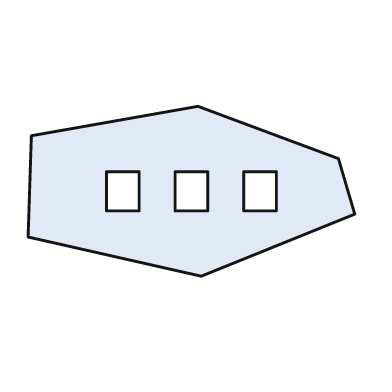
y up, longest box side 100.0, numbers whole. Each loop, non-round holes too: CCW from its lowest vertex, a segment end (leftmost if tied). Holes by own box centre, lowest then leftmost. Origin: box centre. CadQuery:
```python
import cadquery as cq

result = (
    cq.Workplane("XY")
    .moveTo(3.0, -26.0)
    .lineTo(50.0, -7.0)
    .lineTo(45.0, 10.0)
    .lineTo(2.0, 26.0)
    .lineTo(-49.0, 17.0)
    .lineTo(-50.0, -14.0)
    .close()
    .moveTo(-26.0, -6.0)
    .lineTo(-16.0, -6.0)
    .lineTo(-16.0, 6.0)
    .lineTo(-26.0, 6.0)
    .close()
    .moveTo(-5.0, -6.0)
    .lineTo(5.0, -6.0)
    .lineTo(5.0, 6.0)
    .lineTo(-5.0, 6.0)
    .close()
    .moveTo(16.0, -6.0)
    .lineTo(26.0, -6.0)
    .lineTo(26.0, 6.0)
    .lineTo(16.0, 6.0)
    .close()
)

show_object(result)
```